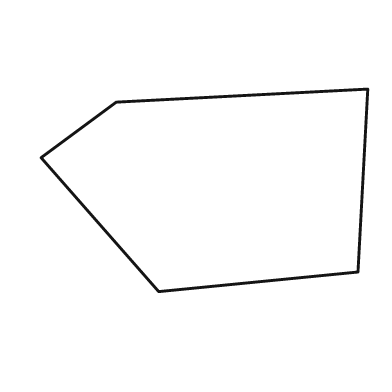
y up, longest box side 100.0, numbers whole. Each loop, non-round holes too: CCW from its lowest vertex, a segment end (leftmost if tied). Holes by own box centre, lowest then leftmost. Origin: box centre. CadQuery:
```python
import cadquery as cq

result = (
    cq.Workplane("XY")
    .moveTo(-14.0, -31.0)
    .lineTo(47.0, -25.0)
    .lineTo(50.0, 31.0)
    .lineTo(-27.0, 27.0)
    .lineTo(-50.0, 10.0)
    .close()
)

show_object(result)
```